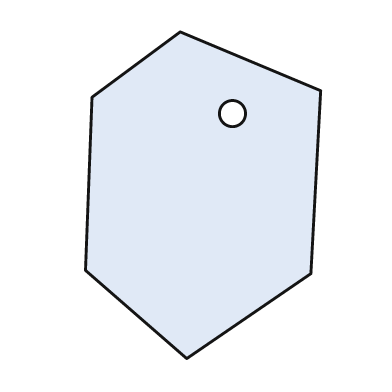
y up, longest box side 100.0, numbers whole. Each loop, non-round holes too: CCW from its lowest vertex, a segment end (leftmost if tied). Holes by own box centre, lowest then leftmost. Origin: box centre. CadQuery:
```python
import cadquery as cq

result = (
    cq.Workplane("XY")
    .moveTo(-5.0, -50.0)
    .lineTo(33.0, -24.0)
    .lineTo(36.0, 32.0)
    .lineTo(-7.0, 50.0)
    .lineTo(-34.0, 30.0)
    .lineTo(-36.0, -23.0)
    .close()
    .moveTo(9.0, 25.0)
    .circle(4.0)
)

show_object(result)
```